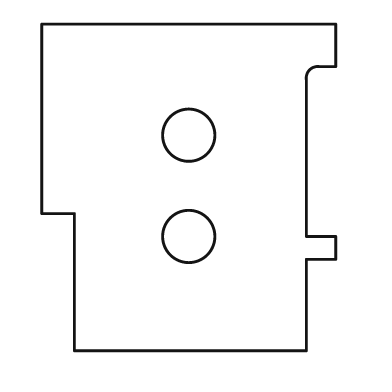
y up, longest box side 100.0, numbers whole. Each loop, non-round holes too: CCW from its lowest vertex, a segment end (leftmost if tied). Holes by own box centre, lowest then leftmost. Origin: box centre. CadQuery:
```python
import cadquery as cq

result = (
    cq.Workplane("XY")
    .moveTo(-35.0, -50.0)
    .lineTo(36.0, -50.0)
    .lineTo(36.0, -22.0)
    .lineTo(45.0, -22.0)
    .lineTo(45.0, -15.0)
    .lineTo(36.0, -15.0)
    .lineTo(36.0, 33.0)
    .threePointArc((37.0, 36.0), (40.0, 37.0))
    .lineTo(45.0, 37.0)
    .lineTo(45.0, 50.0)
    .lineTo(-45.0, 50.0)
    .lineTo(-45.0, -8.0)
    .lineTo(-35.0, -8.0)
    .close()
    .moveTo(0.0, -15.0)
    .circle(8.0)
    .moveTo(0.0, 16.0)
    .circle(8.0)
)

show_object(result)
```